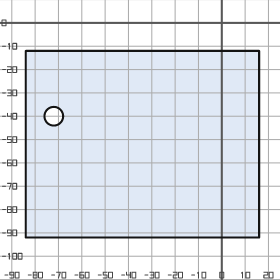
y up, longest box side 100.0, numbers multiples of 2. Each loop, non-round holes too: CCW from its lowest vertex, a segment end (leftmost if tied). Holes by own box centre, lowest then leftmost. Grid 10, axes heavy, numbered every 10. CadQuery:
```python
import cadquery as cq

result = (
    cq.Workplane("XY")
    .moveTo(-84.0, -92.0)
    .lineTo(16.0, -92.0)
    .lineTo(16.0, -12.0)
    .lineTo(-84.0, -12.0)
    .close()
    .moveTo(-72.0, -40.0)
    .circle(4.0)
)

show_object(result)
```